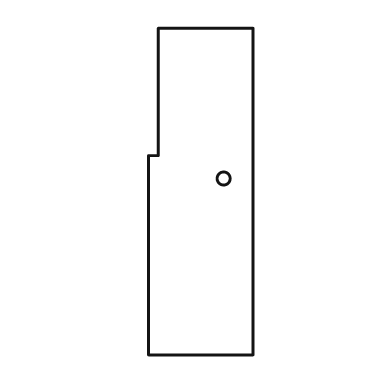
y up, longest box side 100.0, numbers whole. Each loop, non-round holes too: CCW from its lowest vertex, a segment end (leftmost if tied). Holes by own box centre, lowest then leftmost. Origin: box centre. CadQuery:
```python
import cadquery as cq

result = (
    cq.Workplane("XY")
    .moveTo(-16.0, -50.0)
    .lineTo(16.0, -50.0)
    .lineTo(16.0, 50.0)
    .lineTo(-13.0, 50.0)
    .lineTo(-13.0, 11.0)
    .lineTo(-16.0, 11.0)
    .close()
    .moveTo(7.0, 4.0)
    .circle(2.0)
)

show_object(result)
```